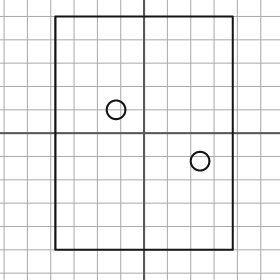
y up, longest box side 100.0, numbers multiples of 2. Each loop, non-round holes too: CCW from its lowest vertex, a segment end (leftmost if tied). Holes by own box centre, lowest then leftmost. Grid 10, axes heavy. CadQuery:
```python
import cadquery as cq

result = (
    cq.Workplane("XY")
    .moveTo(-38.0, -50.0)
    .lineTo(38.0, -50.0)
    .lineTo(38.0, 50.0)
    .lineTo(-38.0, 50.0)
    .close()
    .moveTo(24.0, -12.0)
    .circle(4.0)
    .moveTo(-12.0, 10.0)
    .circle(4.0)
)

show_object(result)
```